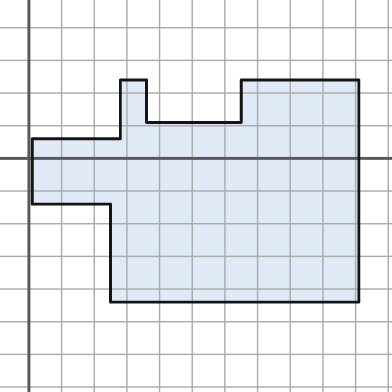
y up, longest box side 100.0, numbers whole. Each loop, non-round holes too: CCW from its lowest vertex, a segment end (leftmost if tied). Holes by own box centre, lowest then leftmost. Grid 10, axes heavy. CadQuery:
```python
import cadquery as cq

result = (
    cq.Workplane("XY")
    .moveTo(25.0, -44.0)
    .lineTo(101.0, -44.0)
    .lineTo(101.0, 24.0)
    .lineTo(65.0, 24.0)
    .lineTo(65.0, 11.0)
    .lineTo(36.0, 11.0)
    .lineTo(36.0, 24.0)
    .lineTo(28.0, 24.0)
    .lineTo(28.0, 6.0)
    .lineTo(1.0, 6.0)
    .lineTo(1.0, -14.0)
    .lineTo(25.0, -14.0)
    .close()
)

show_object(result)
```